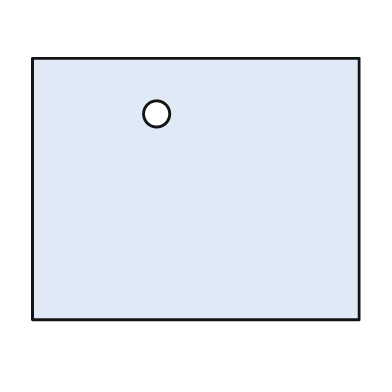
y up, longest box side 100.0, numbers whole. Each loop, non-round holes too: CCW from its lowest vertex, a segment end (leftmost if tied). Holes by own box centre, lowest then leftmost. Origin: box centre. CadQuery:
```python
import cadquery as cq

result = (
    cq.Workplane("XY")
    .moveTo(-50.0, -40.0)
    .lineTo(50.0, -40.0)
    .lineTo(50.0, 40.0)
    .lineTo(-50.0, 40.0)
    .close()
    .moveTo(-12.0, 23.0)
    .circle(4.0)
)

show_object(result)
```